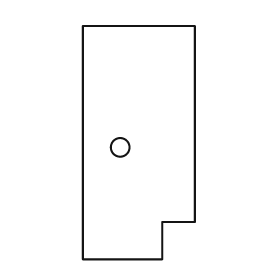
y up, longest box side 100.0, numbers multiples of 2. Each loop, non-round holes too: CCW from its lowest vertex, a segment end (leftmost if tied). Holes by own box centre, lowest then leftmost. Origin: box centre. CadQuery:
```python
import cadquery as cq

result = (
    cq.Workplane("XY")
    .moveTo(-24.0, -50.0)
    .lineTo(10.0, -50.0)
    .lineTo(10.0, -34.0)
    .lineTo(24.0, -34.0)
    .lineTo(24.0, 50.0)
    .lineTo(-24.0, 50.0)
    .close()
    .moveTo(-8.0, -2.0)
    .circle(4.0)
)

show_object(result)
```